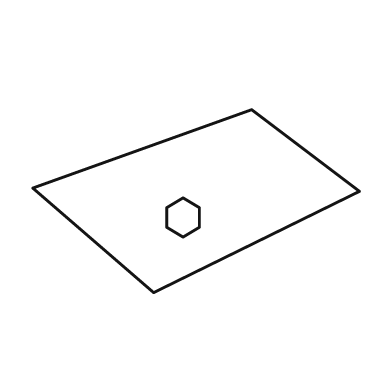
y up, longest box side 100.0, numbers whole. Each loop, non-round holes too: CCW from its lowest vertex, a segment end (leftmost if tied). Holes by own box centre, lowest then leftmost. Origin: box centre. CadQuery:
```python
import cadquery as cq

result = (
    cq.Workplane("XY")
    .moveTo(-13.0, -28.0)
    .lineTo(50.0, 3.0)
    .lineTo(17.0, 28.0)
    .lineTo(-50.0, 4.0)
    .close()
    .moveTo(-4.0, -11.0)
    .lineTo(1.0, -8.0)
    .lineTo(1.0, -2.0)
    .lineTo(-4.0, 1.0)
    .lineTo(-9.0, -2.0)
    .lineTo(-9.0, -8.0)
    .close()
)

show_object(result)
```